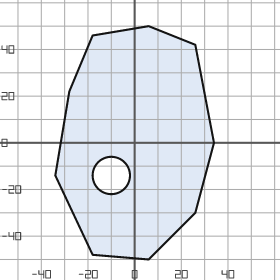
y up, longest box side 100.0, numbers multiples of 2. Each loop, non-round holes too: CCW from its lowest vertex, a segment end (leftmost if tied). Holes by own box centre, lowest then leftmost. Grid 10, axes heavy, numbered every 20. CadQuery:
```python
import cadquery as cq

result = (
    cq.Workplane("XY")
    .moveTo(6.0, -50.0)
    .lineTo(26.0, -30.0)
    .lineTo(34.0, 0.0)
    .lineTo(26.0, 42.0)
    .lineTo(6.0, 50.0)
    .lineTo(-18.0, 46.0)
    .lineTo(-28.0, 22.0)
    .lineTo(-34.0, -14.0)
    .lineTo(-18.0, -48.0)
    .close()
    .moveTo(-10.0, -14.0)
    .circle(8.0)
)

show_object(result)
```